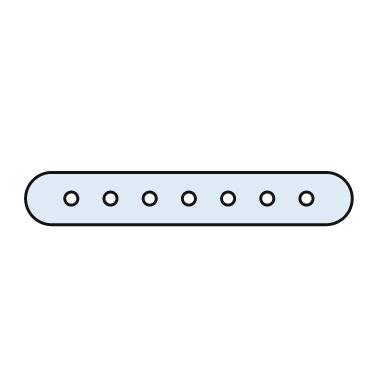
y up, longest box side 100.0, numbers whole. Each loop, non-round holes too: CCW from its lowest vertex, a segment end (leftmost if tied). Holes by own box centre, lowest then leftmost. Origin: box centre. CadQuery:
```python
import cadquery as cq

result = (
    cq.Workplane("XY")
    .moveTo(-42.0, -8.0)
    .lineTo(42.0, -8.0)
    .threePointArc((50.0, 0.0), (42.0, 8.0))
    .lineTo(-42.0, 8.0)
    .threePointArc((-50.0, 0.0), (-42.0, -8.0))
    .close()
    .moveTo(-36.0, 0.0)
    .circle(2.0)
    .moveTo(-24.0, 0.0)
    .circle(2.0)
    .moveTo(-12.0, 0.0)
    .circle(2.0)
    .moveTo(0.0, 0.0)
    .circle(2.0)
    .moveTo(12.0, 0.0)
    .circle(2.0)
    .moveTo(24.0, 0.0)
    .circle(2.0)
    .moveTo(36.0, 0.0)
    .circle(2.0)
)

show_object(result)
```